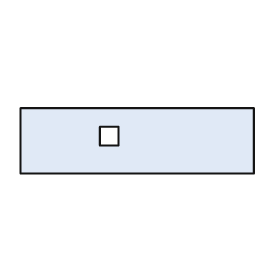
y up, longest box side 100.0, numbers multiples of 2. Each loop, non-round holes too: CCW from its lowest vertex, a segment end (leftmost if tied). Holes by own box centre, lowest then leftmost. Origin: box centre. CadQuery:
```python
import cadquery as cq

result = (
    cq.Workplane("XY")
    .moveTo(-50.0, -14.0)
    .lineTo(50.0, -14.0)
    .lineTo(50.0, 14.0)
    .lineTo(-50.0, 14.0)
    .close()
    .moveTo(-16.0, -2.0)
    .lineTo(-8.0, -2.0)
    .lineTo(-8.0, 6.0)
    .lineTo(-16.0, 6.0)
    .close()
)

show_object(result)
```